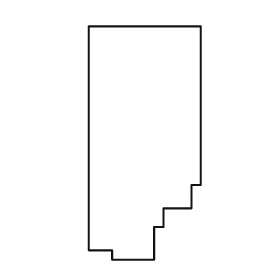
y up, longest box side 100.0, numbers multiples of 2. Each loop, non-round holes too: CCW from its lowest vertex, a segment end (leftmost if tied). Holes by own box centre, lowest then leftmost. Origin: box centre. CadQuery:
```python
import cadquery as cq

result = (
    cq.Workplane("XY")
    .moveTo(-14.0, -50.0)
    .lineTo(4.0, -50.0)
    .lineTo(4.0, -36.0)
    .lineTo(8.0, -36.0)
    .lineTo(8.0, -28.0)
    .lineTo(20.0, -28.0)
    .lineTo(20.0, -18.0)
    .lineTo(24.0, -18.0)
    .lineTo(24.0, 50.0)
    .lineTo(-24.0, 50.0)
    .lineTo(-24.0, -46.0)
    .lineTo(-14.0, -46.0)
    .close()
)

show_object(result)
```